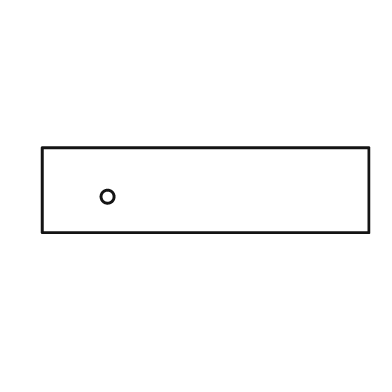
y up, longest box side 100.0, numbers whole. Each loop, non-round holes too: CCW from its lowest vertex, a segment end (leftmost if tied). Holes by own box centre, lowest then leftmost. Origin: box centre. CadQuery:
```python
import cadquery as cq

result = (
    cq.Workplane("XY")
    .moveTo(-50.0, -13.0)
    .lineTo(50.0, -13.0)
    .lineTo(50.0, 13.0)
    .lineTo(-50.0, 13.0)
    .close()
    .moveTo(-30.0, -2.0)
    .circle(2.0)
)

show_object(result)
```